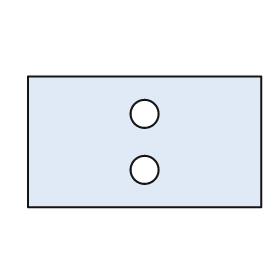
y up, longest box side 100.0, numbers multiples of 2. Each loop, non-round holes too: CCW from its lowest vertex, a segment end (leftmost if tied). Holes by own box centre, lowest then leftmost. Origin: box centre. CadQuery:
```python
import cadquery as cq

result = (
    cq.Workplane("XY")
    .moveTo(-50.0, -28.0)
    .lineTo(50.0, -28.0)
    .lineTo(50.0, 28.0)
    .lineTo(-50.0, 28.0)
    .close()
    .moveTo(0.0, -12.0)
    .circle(6.0)
    .moveTo(0.0, 12.0)
    .circle(6.0)
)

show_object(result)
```